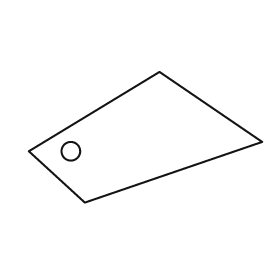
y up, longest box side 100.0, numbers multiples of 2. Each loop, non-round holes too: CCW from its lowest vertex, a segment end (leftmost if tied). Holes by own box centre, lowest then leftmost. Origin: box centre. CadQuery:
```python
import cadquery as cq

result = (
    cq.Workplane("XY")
    .moveTo(-26.0, -28.0)
    .lineTo(50.0, -2.0)
    .lineTo(6.0, 28.0)
    .lineTo(-50.0, -6.0)
    .close()
    .moveTo(-32.0, -6.0)
    .circle(4.0)
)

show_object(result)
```